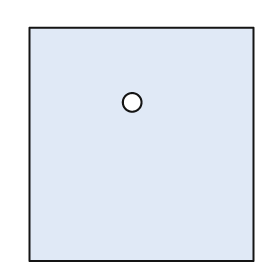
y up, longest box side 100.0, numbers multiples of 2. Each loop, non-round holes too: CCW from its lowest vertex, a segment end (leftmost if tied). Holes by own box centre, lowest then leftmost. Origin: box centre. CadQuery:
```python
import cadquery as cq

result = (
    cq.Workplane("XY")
    .moveTo(-48.0, -50.0)
    .lineTo(48.0, -50.0)
    .lineTo(48.0, 50.0)
    .lineTo(-48.0, 50.0)
    .close()
    .moveTo(-4.0, 18.0)
    .circle(4.0)
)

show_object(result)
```